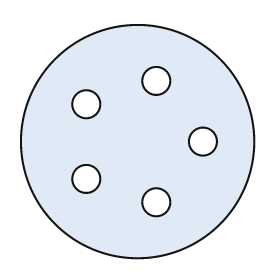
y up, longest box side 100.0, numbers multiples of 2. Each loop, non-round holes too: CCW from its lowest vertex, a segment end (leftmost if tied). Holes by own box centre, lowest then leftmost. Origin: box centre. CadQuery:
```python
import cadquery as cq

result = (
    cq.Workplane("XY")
    .moveTo(0.0, 0.0)
    .circle(50.0)
    .moveTo(8.0, -26.0)
    .circle(6.0)
    .moveTo(-22.0, -16.0)
    .circle(6.0)
    .moveTo(28.0, 0.0)
    .circle(6.0)
    .moveTo(-22.0, 16.0)
    .circle(6.0)
    .moveTo(8.0, 26.0)
    .circle(6.0)
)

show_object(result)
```